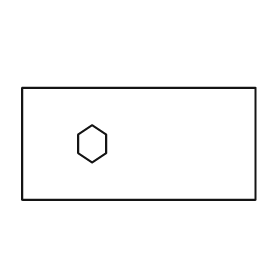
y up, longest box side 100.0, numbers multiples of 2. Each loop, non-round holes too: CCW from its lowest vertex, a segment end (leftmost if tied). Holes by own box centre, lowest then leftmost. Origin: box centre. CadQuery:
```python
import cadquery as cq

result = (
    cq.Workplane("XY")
    .moveTo(-50.0, -24.0)
    .lineTo(50.0, -24.0)
    .lineTo(50.0, 24.0)
    .lineTo(-50.0, 24.0)
    .close()
    .moveTo(-20.0, -8.0)
    .lineTo(-14.0, -4.0)
    .lineTo(-14.0, 4.0)
    .lineTo(-20.0, 8.0)
    .lineTo(-26.0, 4.0)
    .lineTo(-26.0, -4.0)
    .close()
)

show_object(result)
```